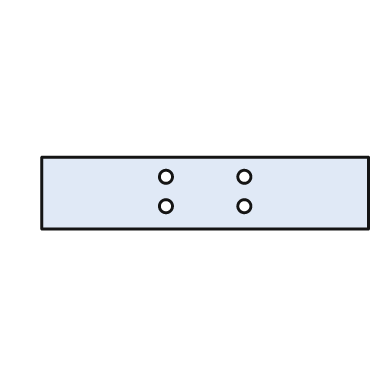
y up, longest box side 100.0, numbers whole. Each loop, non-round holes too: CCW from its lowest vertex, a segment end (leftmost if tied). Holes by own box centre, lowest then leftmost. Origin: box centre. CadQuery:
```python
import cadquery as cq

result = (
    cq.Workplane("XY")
    .moveTo(-50.0, -11.0)
    .lineTo(50.0, -11.0)
    .lineTo(50.0, 11.0)
    .lineTo(-50.0, 11.0)
    .close()
    .moveTo(-12.0, -4.0)
    .circle(2.0)
    .moveTo(12.0, -4.0)
    .circle(2.0)
    .moveTo(-12.0, 5.0)
    .circle(2.0)
    .moveTo(12.0, 5.0)
    .circle(2.0)
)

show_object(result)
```